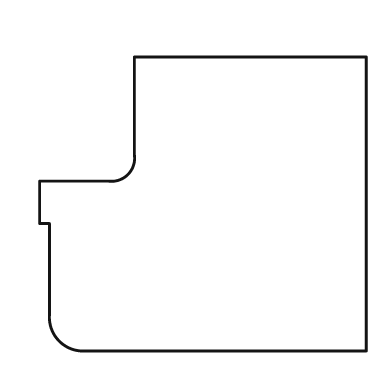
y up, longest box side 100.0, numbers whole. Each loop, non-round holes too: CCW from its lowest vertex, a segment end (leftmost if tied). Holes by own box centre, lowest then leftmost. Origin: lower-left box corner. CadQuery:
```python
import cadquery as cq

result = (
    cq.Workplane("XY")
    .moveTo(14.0, 0.0)
    .lineTo(100.0, 0.0)
    .lineTo(100.0, 90.0)
    .lineTo(29.0, 90.0)
    .lineTo(29.0, 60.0)
    .threePointArc((27.0, 54.0), (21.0, 52.0))
    .lineTo(0.0, 52.0)
    .lineTo(0.0, 39.0)
    .lineTo(3.0, 39.0)
    .lineTo(3.0, 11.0)
    .threePointArc((6.0, 3.0), (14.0, 0.0))
    .close()
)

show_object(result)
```